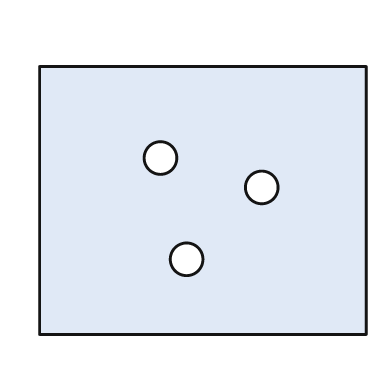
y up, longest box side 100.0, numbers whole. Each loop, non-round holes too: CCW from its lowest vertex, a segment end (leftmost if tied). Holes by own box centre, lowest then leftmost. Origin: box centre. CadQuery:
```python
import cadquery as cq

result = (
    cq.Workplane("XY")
    .moveTo(-50.0, -41.0)
    .lineTo(50.0, -41.0)
    .lineTo(50.0, 41.0)
    .lineTo(-50.0, 41.0)
    .close()
    .moveTo(-5.0, -18.0)
    .circle(5.0)
    .moveTo(18.0, 4.0)
    .circle(5.0)
    .moveTo(-13.0, 13.0)
    .circle(5.0)
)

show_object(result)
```